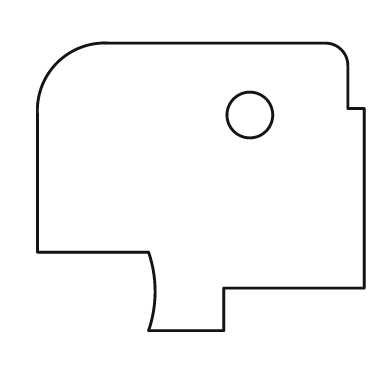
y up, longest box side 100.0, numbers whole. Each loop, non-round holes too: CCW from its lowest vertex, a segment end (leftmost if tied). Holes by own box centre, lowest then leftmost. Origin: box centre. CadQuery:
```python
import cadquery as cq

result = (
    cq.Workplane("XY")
    .moveTo(-16.0, -44.0)
    .lineTo(7.0, -44.0)
    .lineTo(7.0, -31.0)
    .lineTo(50.0, -31.0)
    .lineTo(50.0, 24.0)
    .lineTo(45.0, 24.0)
    .lineTo(45.0, 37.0)
    .threePointArc((43.0, 42.0), (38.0, 44.0))
    .lineTo(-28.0, 44.0)
    .threePointArc((-44.0, 38.0), (-50.0, 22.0))
    .lineTo(-50.0, -20.0)
    .lineTo(-16.0, -20.0)
    .threePointArc((-14.0, -32.0), (-16.0, -44.0))
    .close()
    .moveTo(15.0, 22.0)
    .circle(7.0)
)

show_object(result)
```